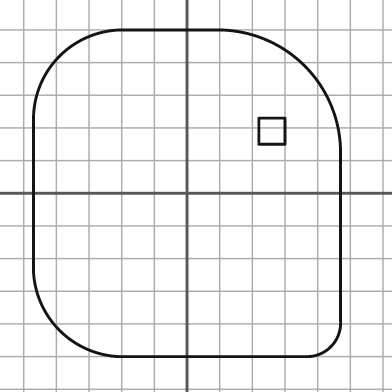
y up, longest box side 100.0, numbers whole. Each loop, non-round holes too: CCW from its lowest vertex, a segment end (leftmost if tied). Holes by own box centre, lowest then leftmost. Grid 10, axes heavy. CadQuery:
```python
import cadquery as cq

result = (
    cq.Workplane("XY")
    .moveTo(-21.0, -50.0)
    .lineTo(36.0, -50.0)
    .threePointArc((44.0, -47.0), (47.0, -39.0))
    .lineTo(47.0, 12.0)
    .threePointArc((36.0, 39.0), (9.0, 50.0))
    .lineTo(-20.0, 50.0)
    .threePointArc((-39.0, 42.0), (-47.0, 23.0))
    .lineTo(-47.0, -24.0)
    .threePointArc((-39.0, -42.0), (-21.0, -50.0))
    .close()
    .moveTo(22.0, 15.0)
    .lineTo(30.0, 15.0)
    .lineTo(30.0, 23.0)
    .lineTo(22.0, 23.0)
    .close()
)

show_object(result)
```